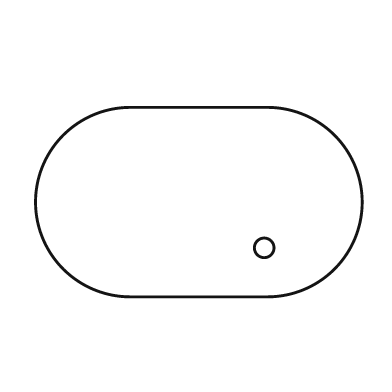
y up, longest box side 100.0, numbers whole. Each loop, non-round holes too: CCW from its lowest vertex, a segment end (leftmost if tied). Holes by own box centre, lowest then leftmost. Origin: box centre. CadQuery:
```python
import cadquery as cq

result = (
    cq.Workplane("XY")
    .moveTo(-21.0, -29.0)
    .lineTo(21.0, -29.0)
    .threePointArc((50.0, 0.0), (21.0, 29.0))
    .lineTo(-21.0, 29.0)
    .threePointArc((-50.0, 0.0), (-21.0, -29.0))
    .close()
    .moveTo(20.0, -14.0)
    .circle(3.0)
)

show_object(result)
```